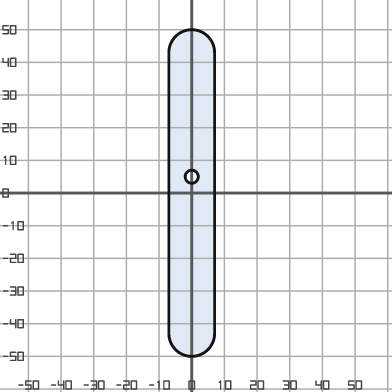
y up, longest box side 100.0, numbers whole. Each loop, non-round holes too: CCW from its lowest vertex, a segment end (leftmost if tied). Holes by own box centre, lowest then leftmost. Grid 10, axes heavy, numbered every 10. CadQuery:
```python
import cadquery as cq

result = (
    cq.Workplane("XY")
    .moveTo(-7.0, -43.0)
    .threePointArc((0.0, -50.0), (7.0, -43.0))
    .lineTo(7.0, 43.0)
    .threePointArc((0.0, 50.0), (-7.0, 43.0))
    .close()
    .moveTo(0.0, 5.0)
    .circle(2.0)
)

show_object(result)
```